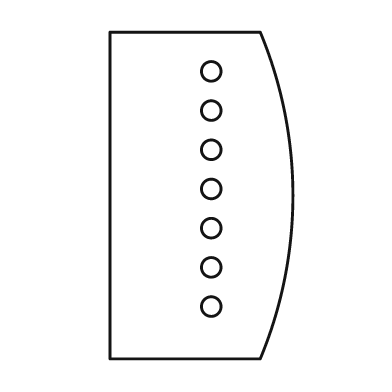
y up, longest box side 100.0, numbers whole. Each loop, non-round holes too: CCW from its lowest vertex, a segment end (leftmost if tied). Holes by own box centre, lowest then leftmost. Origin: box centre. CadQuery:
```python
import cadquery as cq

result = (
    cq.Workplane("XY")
    .moveTo(-28.0, -50.0)
    .lineTo(18.0, -50.0)
    .threePointArc((28.0, 0.0), (18.0, 50.0))
    .lineTo(-28.0, 50.0)
    .close()
    .moveTo(3.0, -34.0)
    .circle(3.0)
    .moveTo(3.0, -22.0)
    .circle(3.0)
    .moveTo(3.0, -10.0)
    .circle(3.0)
    .moveTo(3.0, 2.0)
    .circle(3.0)
    .moveTo(3.0, 14.0)
    .circle(3.0)
    .moveTo(3.0, 26.0)
    .circle(3.0)
    .moveTo(3.0, 38.0)
    .circle(3.0)
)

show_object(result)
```